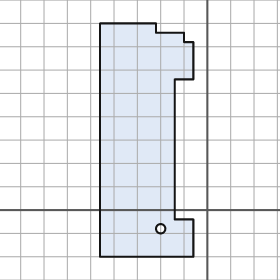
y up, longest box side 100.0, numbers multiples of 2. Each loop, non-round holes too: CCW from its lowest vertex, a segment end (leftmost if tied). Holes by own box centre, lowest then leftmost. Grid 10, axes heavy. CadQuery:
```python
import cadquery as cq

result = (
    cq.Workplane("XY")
    .moveTo(-46.0, -20.0)
    .lineTo(-6.0, -20.0)
    .lineTo(-6.0, -4.0)
    .lineTo(-14.0, -4.0)
    .lineTo(-14.0, 56.0)
    .lineTo(-6.0, 56.0)
    .lineTo(-6.0, 72.0)
    .lineTo(-10.0, 72.0)
    .lineTo(-10.0, 76.0)
    .lineTo(-22.0, 76.0)
    .lineTo(-22.0, 80.0)
    .lineTo(-46.0, 80.0)
    .close()
    .moveTo(-20.0, -8.0)
    .circle(2.0)
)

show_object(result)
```